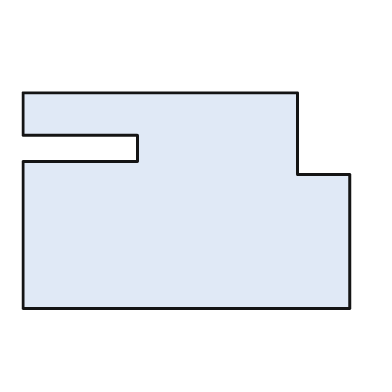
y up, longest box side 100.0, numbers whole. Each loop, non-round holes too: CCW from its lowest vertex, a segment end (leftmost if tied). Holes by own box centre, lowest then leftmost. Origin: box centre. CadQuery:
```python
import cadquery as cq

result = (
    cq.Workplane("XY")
    .moveTo(-50.0, -33.0)
    .lineTo(50.0, -33.0)
    .lineTo(50.0, 8.0)
    .lineTo(34.0, 8.0)
    .lineTo(34.0, 33.0)
    .lineTo(-50.0, 33.0)
    .lineTo(-50.0, 20.0)
    .lineTo(-15.0, 20.0)
    .lineTo(-15.0, 12.0)
    .lineTo(-50.0, 12.0)
    .close()
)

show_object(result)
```